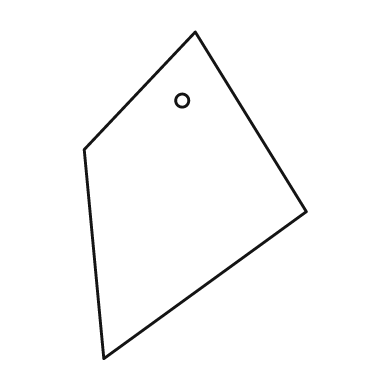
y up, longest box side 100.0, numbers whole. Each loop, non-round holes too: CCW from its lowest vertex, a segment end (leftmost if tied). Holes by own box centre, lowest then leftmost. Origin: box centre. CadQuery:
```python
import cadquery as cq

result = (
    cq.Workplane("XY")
    .moveTo(-28.0, -50.0)
    .lineTo(34.0, -5.0)
    .lineTo(0.0, 50.0)
    .lineTo(-34.0, 14.0)
    .close()
    .moveTo(-4.0, 29.0)
    .circle(2.0)
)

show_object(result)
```